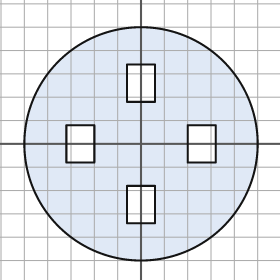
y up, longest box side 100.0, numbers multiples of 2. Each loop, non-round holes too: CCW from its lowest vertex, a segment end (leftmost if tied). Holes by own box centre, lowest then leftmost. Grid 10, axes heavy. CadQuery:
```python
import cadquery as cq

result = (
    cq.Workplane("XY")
    .moveTo(0.0, 0.0)
    .circle(50.0)
    .moveTo(-6.0, -34.0)
    .lineTo(6.0, -34.0)
    .lineTo(6.0, -18.0)
    .lineTo(-6.0, -18.0)
    .close()
    .moveTo(-32.0, -8.0)
    .lineTo(-20.0, -8.0)
    .lineTo(-20.0, 8.0)
    .lineTo(-32.0, 8.0)
    .close()
    .moveTo(20.0, -8.0)
    .lineTo(32.0, -8.0)
    .lineTo(32.0, 8.0)
    .lineTo(20.0, 8.0)
    .close()
    .moveTo(-6.0, 18.0)
    .lineTo(6.0, 18.0)
    .lineTo(6.0, 34.0)
    .lineTo(-6.0, 34.0)
    .close()
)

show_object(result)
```